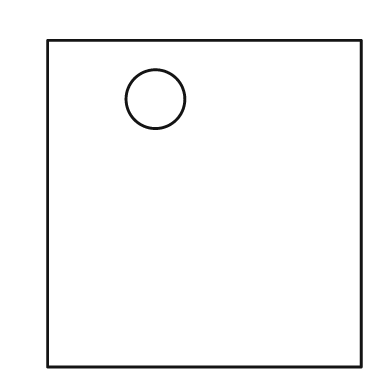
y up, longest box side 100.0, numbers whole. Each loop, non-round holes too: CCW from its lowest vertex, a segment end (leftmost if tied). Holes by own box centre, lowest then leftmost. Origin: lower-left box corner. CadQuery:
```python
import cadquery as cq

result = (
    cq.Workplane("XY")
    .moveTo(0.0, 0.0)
    .lineTo(96.0, 0.0)
    .lineTo(96.0, 100.0)
    .lineTo(0.0, 100.0)
    .close()
    .moveTo(33.0, 82.0)
    .circle(9.0)
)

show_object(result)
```